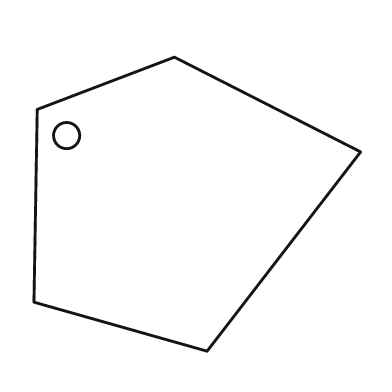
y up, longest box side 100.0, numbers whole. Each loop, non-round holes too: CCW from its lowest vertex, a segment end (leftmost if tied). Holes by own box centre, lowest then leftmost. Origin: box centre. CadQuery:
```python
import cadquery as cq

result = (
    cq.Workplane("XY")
    .moveTo(3.0, -45.0)
    .lineTo(50.0, 16.0)
    .lineTo(-7.0, 45.0)
    .lineTo(-49.0, 29.0)
    .lineTo(-50.0, -30.0)
    .close()
    .moveTo(-40.0, 21.0)
    .circle(4.0)
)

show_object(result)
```